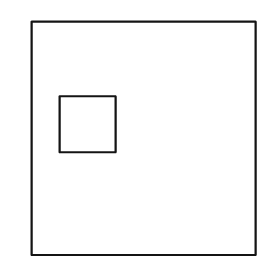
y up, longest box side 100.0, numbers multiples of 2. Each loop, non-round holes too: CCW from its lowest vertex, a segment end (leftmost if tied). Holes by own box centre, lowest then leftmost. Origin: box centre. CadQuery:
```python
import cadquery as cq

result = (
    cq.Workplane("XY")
    .moveTo(-48.0, -50.0)
    .lineTo(48.0, -50.0)
    .lineTo(48.0, 50.0)
    .lineTo(-48.0, 50.0)
    .close()
    .moveTo(-36.0, -6.0)
    .lineTo(-12.0, -6.0)
    .lineTo(-12.0, 18.0)
    .lineTo(-36.0, 18.0)
    .close()
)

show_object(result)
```